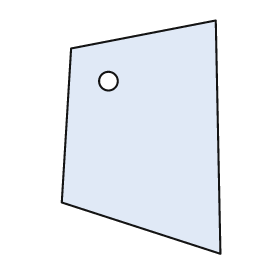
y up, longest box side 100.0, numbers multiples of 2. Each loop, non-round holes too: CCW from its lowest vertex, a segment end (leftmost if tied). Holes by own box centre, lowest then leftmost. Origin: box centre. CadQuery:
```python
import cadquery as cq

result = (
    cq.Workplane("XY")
    .moveTo(34.0, -50.0)
    .lineTo(32.0, 50.0)
    .lineTo(-30.0, 38.0)
    .lineTo(-34.0, -28.0)
    .close()
    .moveTo(-14.0, 24.0)
    .circle(4.0)
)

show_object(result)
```